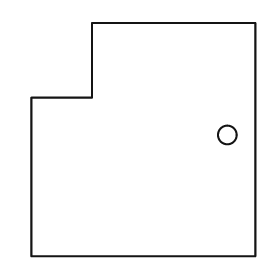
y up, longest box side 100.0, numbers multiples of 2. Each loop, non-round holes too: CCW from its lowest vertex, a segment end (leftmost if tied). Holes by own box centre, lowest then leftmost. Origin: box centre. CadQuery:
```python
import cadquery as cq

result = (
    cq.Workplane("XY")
    .moveTo(-48.0, -50.0)
    .lineTo(48.0, -50.0)
    .lineTo(48.0, 50.0)
    .lineTo(-22.0, 50.0)
    .lineTo(-22.0, 18.0)
    .lineTo(-48.0, 18.0)
    .close()
    .moveTo(36.0, 2.0)
    .circle(4.0)
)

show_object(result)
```